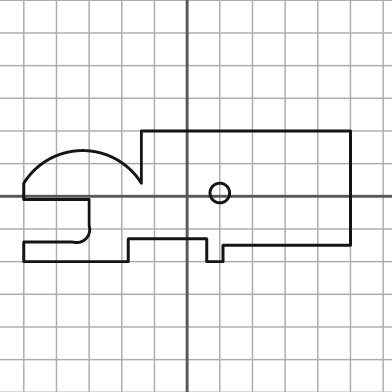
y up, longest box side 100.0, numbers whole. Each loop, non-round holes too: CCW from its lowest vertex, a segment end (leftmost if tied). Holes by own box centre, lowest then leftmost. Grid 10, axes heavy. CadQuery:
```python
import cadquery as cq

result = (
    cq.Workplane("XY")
    .moveTo(-50.0, -20.0)
    .lineTo(-18.0, -20.0)
    .lineTo(-18.0, -13.0)
    .lineTo(6.0, -13.0)
    .lineTo(6.0, -20.0)
    .lineTo(11.0, -20.0)
    .lineTo(11.0, -15.0)
    .lineTo(50.0, -15.0)
    .lineTo(50.0, 20.0)
    .lineTo(-14.0, 20.0)
    .lineTo(-14.0, 4.0)
    .threePointArc((-32.0, 14.0), (-50.0, 4.0))
    .lineTo(-50.0, -1.0)
    .lineTo(-30.0, -1.0)
    .lineTo(-30.0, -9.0)
    .threePointArc((-31.0, -13.0), (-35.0, -14.0))
    .lineTo(-50.0, -14.0)
    .close()
    .moveTo(10.0, 1.0)
    .circle(3.0)
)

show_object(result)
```